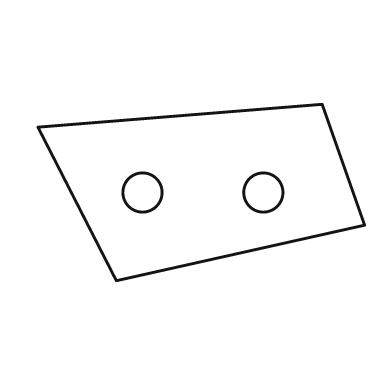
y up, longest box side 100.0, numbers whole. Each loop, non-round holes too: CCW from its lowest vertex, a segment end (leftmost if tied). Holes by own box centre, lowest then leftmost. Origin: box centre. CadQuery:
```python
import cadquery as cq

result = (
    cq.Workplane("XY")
    .moveTo(-26.0, -27.0)
    .lineTo(50.0, -10.0)
    .lineTo(37.0, 27.0)
    .lineTo(-50.0, 20.0)
    .close()
    .moveTo(-18.0, 0.0)
    .circle(6.0)
    .moveTo(19.0, 0.0)
    .circle(6.0)
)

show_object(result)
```